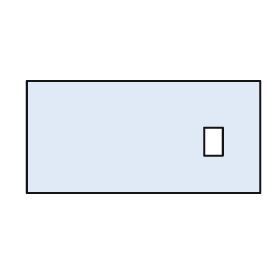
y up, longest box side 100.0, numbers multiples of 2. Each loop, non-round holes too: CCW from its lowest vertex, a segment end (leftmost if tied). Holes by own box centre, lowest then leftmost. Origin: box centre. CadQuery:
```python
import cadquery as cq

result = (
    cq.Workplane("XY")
    .moveTo(-50.0, -24.0)
    .lineTo(50.0, -24.0)
    .lineTo(50.0, 24.0)
    .lineTo(-50.0, 24.0)
    .close()
    .moveTo(26.0, -8.0)
    .lineTo(34.0, -8.0)
    .lineTo(34.0, 4.0)
    .lineTo(26.0, 4.0)
    .close()
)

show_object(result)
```